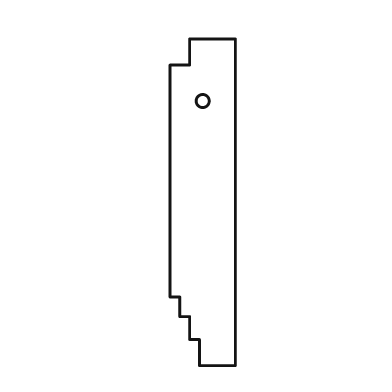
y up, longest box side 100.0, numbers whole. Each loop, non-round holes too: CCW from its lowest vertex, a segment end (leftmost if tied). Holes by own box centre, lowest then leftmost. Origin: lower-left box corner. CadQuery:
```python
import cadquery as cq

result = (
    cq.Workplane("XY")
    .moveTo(9.0, 0.0)
    .lineTo(20.0, 0.0)
    .lineTo(20.0, 100.0)
    .lineTo(6.0, 100.0)
    .lineTo(6.0, 92.0)
    .lineTo(0.0, 92.0)
    .lineTo(0.0, 21.0)
    .lineTo(3.0, 21.0)
    .lineTo(3.0, 15.0)
    .lineTo(6.0, 15.0)
    .lineTo(6.0, 8.0)
    .lineTo(9.0, 8.0)
    .close()
    .moveTo(10.0, 81.0)
    .circle(2.0)
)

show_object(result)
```